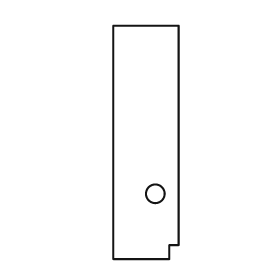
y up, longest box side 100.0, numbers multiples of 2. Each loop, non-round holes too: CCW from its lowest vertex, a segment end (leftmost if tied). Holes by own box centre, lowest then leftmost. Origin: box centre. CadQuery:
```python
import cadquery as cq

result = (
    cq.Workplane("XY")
    .moveTo(-14.0, -50.0)
    .lineTo(10.0, -50.0)
    .lineTo(10.0, -44.0)
    .lineTo(14.0, -44.0)
    .lineTo(14.0, 50.0)
    .lineTo(-14.0, 50.0)
    .close()
    .moveTo(4.0, -22.0)
    .circle(4.0)
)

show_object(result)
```